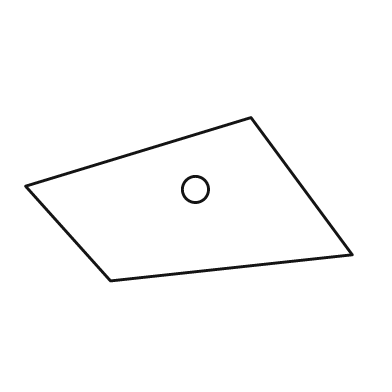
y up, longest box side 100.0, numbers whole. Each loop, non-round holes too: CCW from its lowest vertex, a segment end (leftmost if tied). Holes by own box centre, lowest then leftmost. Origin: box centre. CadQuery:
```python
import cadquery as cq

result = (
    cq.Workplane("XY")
    .moveTo(-24.0, -25.0)
    .lineTo(50.0, -17.0)
    .lineTo(19.0, 25.0)
    .lineTo(-50.0, 4.0)
    .close()
    .moveTo(2.0, 3.0)
    .circle(4.0)
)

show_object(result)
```